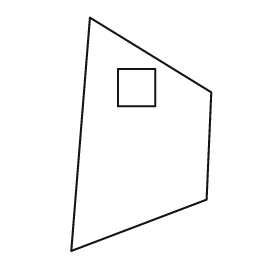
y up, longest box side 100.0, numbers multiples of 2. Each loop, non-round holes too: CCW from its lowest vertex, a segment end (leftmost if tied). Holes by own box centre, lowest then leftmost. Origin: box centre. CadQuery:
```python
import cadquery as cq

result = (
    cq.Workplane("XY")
    .moveTo(-30.0, -50.0)
    .lineTo(28.0, -28.0)
    .lineTo(30.0, 18.0)
    .lineTo(-22.0, 50.0)
    .close()
    .moveTo(-10.0, 12.0)
    .lineTo(6.0, 12.0)
    .lineTo(6.0, 28.0)
    .lineTo(-10.0, 28.0)
    .close()
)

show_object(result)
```